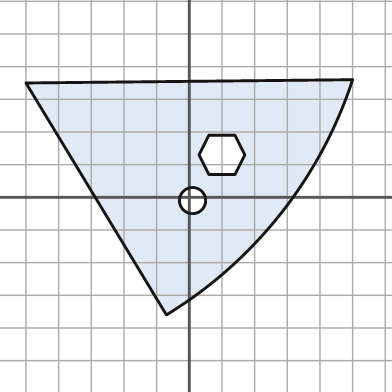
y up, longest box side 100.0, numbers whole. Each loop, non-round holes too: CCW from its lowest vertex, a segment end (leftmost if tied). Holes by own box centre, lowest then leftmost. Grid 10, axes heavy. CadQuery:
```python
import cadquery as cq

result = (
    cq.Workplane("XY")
    .moveTo(-7.0, -36.0)
    .threePointArc((28.0, -5.0), (50.0, 36.0))
    .lineTo(-50.0, 35.0)
    .close()
    .moveTo(1.0, -1.0)
    .circle(4.0)
    .moveTo(6.0, 7.0)
    .lineTo(14.0, 7.0)
    .lineTo(17.0, 13.0)
    .lineTo(14.0, 19.0)
    .lineTo(6.0, 19.0)
    .lineTo(3.0, 13.0)
    .close()
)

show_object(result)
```